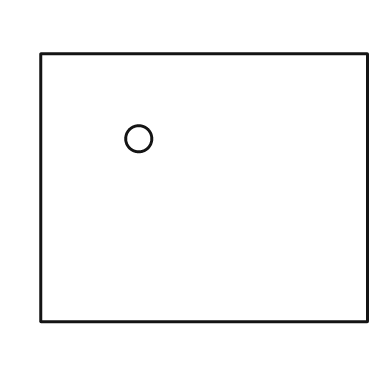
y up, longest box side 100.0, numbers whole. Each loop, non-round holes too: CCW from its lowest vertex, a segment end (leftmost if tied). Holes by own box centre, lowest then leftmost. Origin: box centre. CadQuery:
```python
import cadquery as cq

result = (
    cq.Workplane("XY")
    .moveTo(-50.0, -41.0)
    .lineTo(50.0, -41.0)
    .lineTo(50.0, 41.0)
    .lineTo(-50.0, 41.0)
    .close()
    .moveTo(-20.0, 15.0)
    .circle(4.0)
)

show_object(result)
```